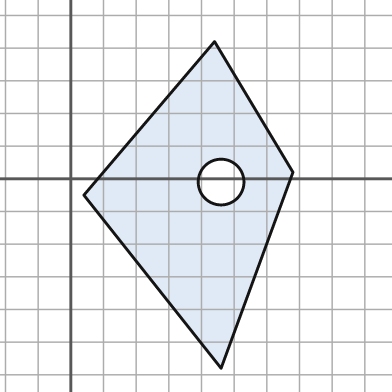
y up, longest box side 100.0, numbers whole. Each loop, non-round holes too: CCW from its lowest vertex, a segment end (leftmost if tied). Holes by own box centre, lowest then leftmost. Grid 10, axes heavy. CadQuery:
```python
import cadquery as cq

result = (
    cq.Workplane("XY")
    .moveTo(46.0, -58.0)
    .lineTo(68.0, 2.0)
    .lineTo(44.0, 42.0)
    .lineTo(4.0, -5.0)
    .close()
    .moveTo(46.0, -1.0)
    .circle(7.0)
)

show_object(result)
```